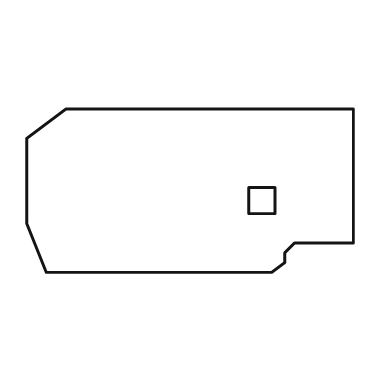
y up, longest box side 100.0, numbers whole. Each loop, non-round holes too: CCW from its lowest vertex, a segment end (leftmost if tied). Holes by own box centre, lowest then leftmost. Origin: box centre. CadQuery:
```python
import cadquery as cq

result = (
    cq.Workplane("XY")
    .moveTo(-44.0, -25.0)
    .lineTo(25.0, -25.0)
    .lineTo(29.0, -22.0)
    .lineTo(29.0, -19.0)
    .lineTo(32.0, -16.0)
    .lineTo(50.0, -16.0)
    .lineTo(50.0, 25.0)
    .lineTo(-38.0, 25.0)
    .lineTo(-50.0, 16.0)
    .lineTo(-50.0, -10.0)
    .close()
    .moveTo(18.0, -7.0)
    .lineTo(26.0, -7.0)
    .lineTo(26.0, 1.0)
    .lineTo(18.0, 1.0)
    .close()
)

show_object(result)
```